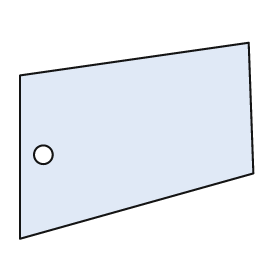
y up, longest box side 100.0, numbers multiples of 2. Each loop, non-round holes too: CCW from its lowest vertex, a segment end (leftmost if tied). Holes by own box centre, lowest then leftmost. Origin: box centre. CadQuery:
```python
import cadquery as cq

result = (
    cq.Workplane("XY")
    .moveTo(-50.0, -42.0)
    .lineTo(50.0, -14.0)
    .lineTo(48.0, 42.0)
    .lineTo(-50.0, 28.0)
    .close()
    .moveTo(-40.0, -6.0)
    .circle(4.0)
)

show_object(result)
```